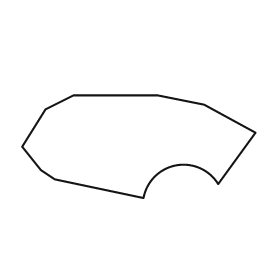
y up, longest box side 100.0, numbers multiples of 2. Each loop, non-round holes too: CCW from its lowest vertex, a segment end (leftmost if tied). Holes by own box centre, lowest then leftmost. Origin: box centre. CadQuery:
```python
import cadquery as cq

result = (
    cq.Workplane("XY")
    .moveTo(2.0, -22.0)
    .threePointArc((16.0, -8.0), (34.0, -16.0))
    .lineTo(50.0, 6.0)
    .lineTo(28.0, 18.0)
    .lineTo(8.0, 22.0)
    .lineTo(-28.0, 22.0)
    .lineTo(-40.0, 16.0)
    .lineTo(-50.0, 0.0)
    .lineTo(-42.0, -10.0)
    .lineTo(-36.0, -14.0)
    .close()
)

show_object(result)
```